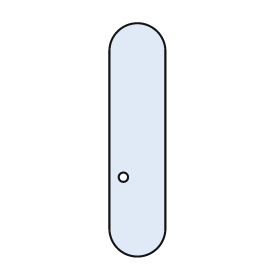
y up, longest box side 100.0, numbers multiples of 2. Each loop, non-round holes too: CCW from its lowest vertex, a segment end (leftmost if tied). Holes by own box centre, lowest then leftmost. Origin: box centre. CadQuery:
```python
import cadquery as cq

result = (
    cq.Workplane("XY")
    .moveTo(-12.0, -38.0)
    .threePointArc((0.0, -50.0), (12.0, -38.0))
    .lineTo(12.0, 38.0)
    .threePointArc((0.0, 50.0), (-12.0, 38.0))
    .close()
    .moveTo(-6.0, -16.0)
    .circle(2.0)
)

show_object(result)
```